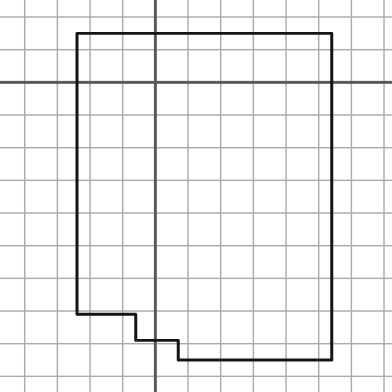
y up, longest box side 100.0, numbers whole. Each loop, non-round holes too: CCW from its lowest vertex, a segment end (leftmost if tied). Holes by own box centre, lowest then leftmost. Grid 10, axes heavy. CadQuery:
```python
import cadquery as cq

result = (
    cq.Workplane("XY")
    .moveTo(7.0, -85.0)
    .lineTo(54.0, -85.0)
    .lineTo(54.0, 15.0)
    .lineTo(-24.0, 15.0)
    .lineTo(-24.0, -71.0)
    .lineTo(-6.0, -71.0)
    .lineTo(-6.0, -79.0)
    .lineTo(7.0, -79.0)
    .close()
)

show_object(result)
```